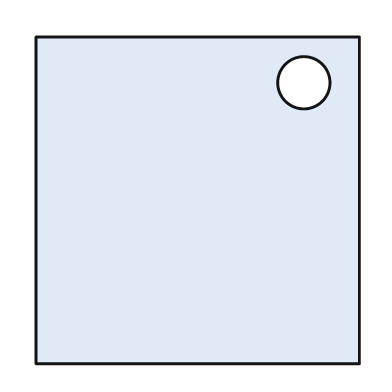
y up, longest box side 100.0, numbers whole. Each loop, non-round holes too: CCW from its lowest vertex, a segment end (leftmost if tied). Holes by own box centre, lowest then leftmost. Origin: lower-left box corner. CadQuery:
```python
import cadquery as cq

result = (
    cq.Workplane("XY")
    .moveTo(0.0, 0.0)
    .lineTo(99.0, 0.0)
    .lineTo(99.0, 100.0)
    .lineTo(0.0, 100.0)
    .close()
    .moveTo(82.0, 86.0)
    .circle(8.0)
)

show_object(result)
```